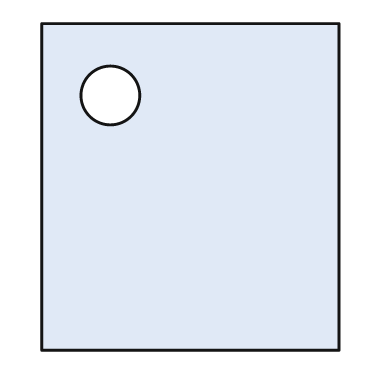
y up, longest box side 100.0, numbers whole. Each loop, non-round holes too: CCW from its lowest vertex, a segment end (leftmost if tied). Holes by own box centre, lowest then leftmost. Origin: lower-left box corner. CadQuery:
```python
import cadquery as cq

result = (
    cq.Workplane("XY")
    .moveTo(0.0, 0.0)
    .lineTo(91.0, 0.0)
    .lineTo(91.0, 100.0)
    .lineTo(0.0, 100.0)
    .close()
    .moveTo(21.0, 78.0)
    .circle(9.0)
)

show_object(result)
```